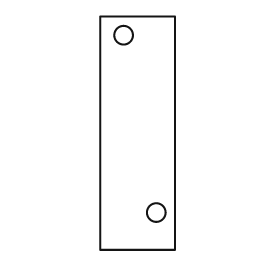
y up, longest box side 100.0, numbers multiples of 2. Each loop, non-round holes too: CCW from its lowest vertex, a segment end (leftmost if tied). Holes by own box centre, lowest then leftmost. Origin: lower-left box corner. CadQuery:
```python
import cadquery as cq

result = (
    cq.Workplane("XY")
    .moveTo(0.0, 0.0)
    .lineTo(32.0, 0.0)
    .lineTo(32.0, 100.0)
    .lineTo(0.0, 100.0)
    .close()
    .moveTo(24.0, 16.0)
    .circle(4.0)
    .moveTo(10.0, 92.0)
    .circle(4.0)
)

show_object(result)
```